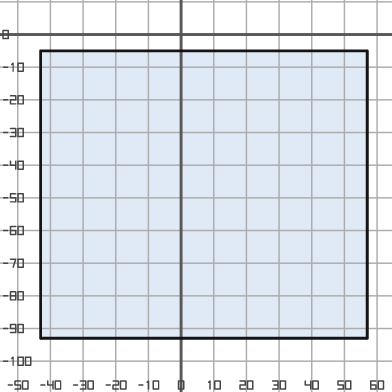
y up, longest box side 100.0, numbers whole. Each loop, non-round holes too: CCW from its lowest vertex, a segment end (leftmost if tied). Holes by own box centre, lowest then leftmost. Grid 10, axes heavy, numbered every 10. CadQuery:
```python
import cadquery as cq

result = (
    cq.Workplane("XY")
    .moveTo(-43.0, -93.0)
    .lineTo(57.0, -93.0)
    .lineTo(57.0, -5.0)
    .lineTo(-43.0, -5.0)
    .close()
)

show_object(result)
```